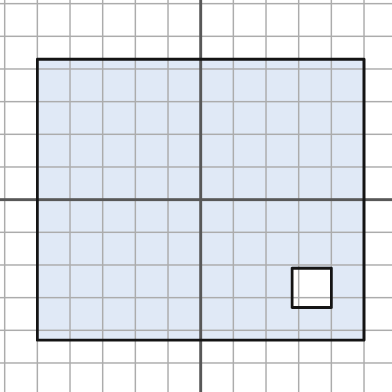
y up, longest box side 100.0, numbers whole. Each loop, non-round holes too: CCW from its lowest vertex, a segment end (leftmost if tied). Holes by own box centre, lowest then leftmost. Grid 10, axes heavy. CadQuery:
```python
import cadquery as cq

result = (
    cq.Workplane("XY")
    .moveTo(-50.0, -43.0)
    .lineTo(50.0, -43.0)
    .lineTo(50.0, 43.0)
    .lineTo(-50.0, 43.0)
    .close()
    .moveTo(28.0, -33.0)
    .lineTo(40.0, -33.0)
    .lineTo(40.0, -21.0)
    .lineTo(28.0, -21.0)
    .close()
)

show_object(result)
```